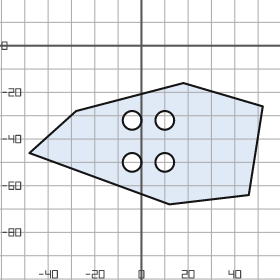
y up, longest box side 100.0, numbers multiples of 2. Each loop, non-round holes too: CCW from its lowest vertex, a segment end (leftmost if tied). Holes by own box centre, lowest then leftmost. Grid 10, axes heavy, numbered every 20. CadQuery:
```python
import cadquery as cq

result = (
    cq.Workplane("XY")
    .moveTo(12.0, -68.0)
    .lineTo(46.0, -64.0)
    .lineTo(52.0, -26.0)
    .lineTo(18.0, -16.0)
    .lineTo(-28.0, -28.0)
    .lineTo(-48.0, -46.0)
    .close()
    .moveTo(-4.0, -50.0)
    .circle(4.0)
    .moveTo(10.0, -50.0)
    .circle(4.0)
    .moveTo(-4.0, -32.0)
    .circle(4.0)
    .moveTo(10.0, -32.0)
    .circle(4.0)
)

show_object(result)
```